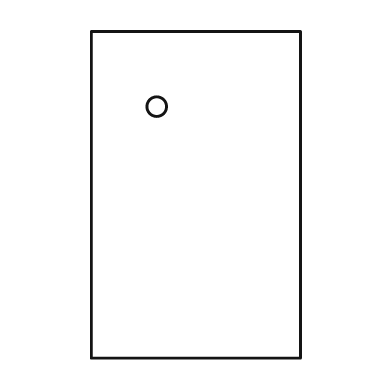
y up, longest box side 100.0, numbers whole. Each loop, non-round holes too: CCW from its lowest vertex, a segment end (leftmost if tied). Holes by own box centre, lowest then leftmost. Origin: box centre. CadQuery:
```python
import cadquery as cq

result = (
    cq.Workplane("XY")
    .moveTo(-32.0, -50.0)
    .lineTo(32.0, -50.0)
    .lineTo(32.0, 50.0)
    .lineTo(-32.0, 50.0)
    .close()
    .moveTo(-12.0, 27.0)
    .circle(3.0)
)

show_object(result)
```